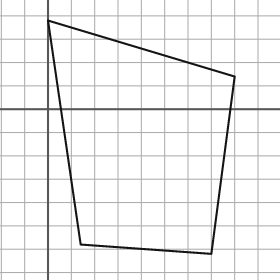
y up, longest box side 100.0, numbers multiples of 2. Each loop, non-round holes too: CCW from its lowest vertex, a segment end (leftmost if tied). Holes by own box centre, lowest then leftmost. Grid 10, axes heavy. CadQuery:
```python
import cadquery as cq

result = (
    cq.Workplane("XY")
    .moveTo(70.0, -62.0)
    .lineTo(80.0, 14.0)
    .lineTo(0.0, 38.0)
    .lineTo(14.0, -58.0)
    .close()
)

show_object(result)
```